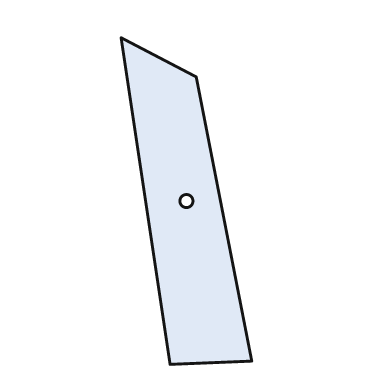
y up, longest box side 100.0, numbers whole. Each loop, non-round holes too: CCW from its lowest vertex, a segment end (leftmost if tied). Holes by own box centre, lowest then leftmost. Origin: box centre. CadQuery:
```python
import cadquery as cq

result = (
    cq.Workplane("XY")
    .moveTo(-5.0, -50.0)
    .lineTo(20.0, -49.0)
    .lineTo(3.0, 38.0)
    .lineTo(-20.0, 50.0)
    .close()
    .moveTo(0.0, 0.0)
    .circle(2.0)
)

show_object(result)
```